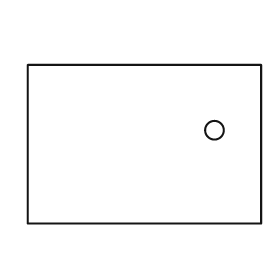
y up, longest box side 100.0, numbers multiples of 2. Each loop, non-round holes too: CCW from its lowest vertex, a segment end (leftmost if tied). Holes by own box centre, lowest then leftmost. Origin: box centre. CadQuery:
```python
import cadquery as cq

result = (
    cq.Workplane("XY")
    .moveTo(-50.0, -34.0)
    .lineTo(50.0, -34.0)
    .lineTo(50.0, 34.0)
    .lineTo(-50.0, 34.0)
    .close()
    .moveTo(30.0, 6.0)
    .circle(4.0)
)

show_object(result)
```